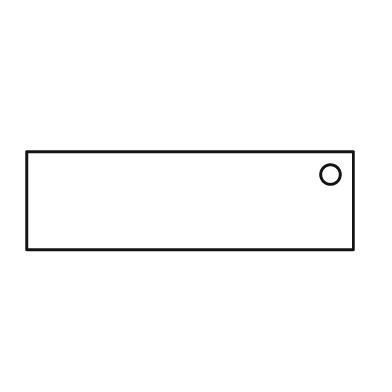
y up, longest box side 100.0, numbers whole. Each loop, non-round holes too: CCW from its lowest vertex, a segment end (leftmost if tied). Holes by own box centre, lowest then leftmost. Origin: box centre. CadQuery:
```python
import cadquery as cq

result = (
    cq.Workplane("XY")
    .moveTo(-50.0, -15.0)
    .lineTo(50.0, -15.0)
    .lineTo(50.0, 15.0)
    .lineTo(-50.0, 15.0)
    .close()
    .moveTo(43.0, 8.0)
    .circle(3.0)
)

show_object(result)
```